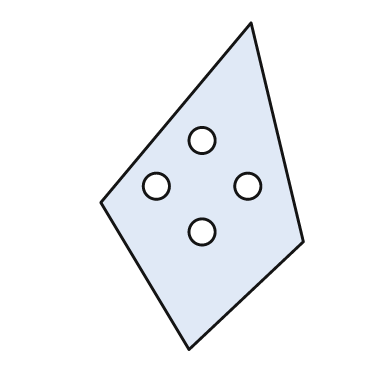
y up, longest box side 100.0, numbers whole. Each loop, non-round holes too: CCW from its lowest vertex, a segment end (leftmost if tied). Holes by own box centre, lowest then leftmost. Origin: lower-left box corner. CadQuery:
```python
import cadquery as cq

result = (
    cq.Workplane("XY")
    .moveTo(27.0, 0.0)
    .lineTo(62.0, 33.0)
    .lineTo(46.0, 100.0)
    .lineTo(0.0, 45.0)
    .close()
    .moveTo(31.0, 36.0)
    .circle(4.0)
    .moveTo(17.0, 50.0)
    .circle(4.0)
    .moveTo(45.0, 50.0)
    .circle(4.0)
    .moveTo(31.0, 64.0)
    .circle(4.0)
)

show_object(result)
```